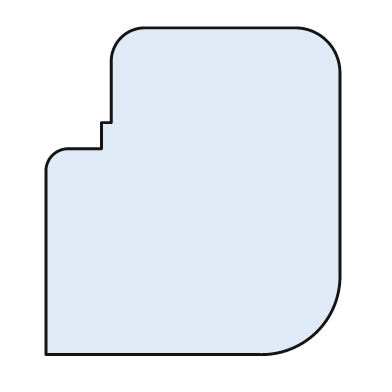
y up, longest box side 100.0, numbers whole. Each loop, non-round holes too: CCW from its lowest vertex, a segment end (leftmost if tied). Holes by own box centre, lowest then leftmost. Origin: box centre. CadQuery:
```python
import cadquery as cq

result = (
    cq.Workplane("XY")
    .moveTo(-45.0, -50.0)
    .lineTo(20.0, -50.0)
    .threePointArc((38.0, -43.0), (45.0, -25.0))
    .lineTo(45.0, 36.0)
    .threePointArc((41.0, 46.0), (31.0, 50.0))
    .lineTo(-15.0, 50.0)
    .threePointArc((-22.0, 47.0), (-25.0, 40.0))
    .lineTo(-25.0, 21.0)
    .lineTo(-28.0, 21.0)
    .lineTo(-28.0, 13.0)
    .lineTo(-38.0, 13.0)
    .threePointArc((-43.0, 11.0), (-45.0, 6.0))
    .close()
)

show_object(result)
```